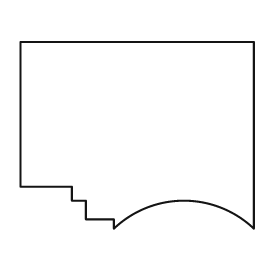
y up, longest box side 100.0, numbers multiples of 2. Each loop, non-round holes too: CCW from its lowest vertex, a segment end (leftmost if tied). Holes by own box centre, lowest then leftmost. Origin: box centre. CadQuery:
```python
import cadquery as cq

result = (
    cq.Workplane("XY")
    .moveTo(-10.0, -40.0)
    .threePointArc((20.0, -28.0), (50.0, -40.0))
    .lineTo(50.0, 40.0)
    .lineTo(-50.0, 40.0)
    .lineTo(-50.0, -22.0)
    .lineTo(-28.0, -22.0)
    .lineTo(-28.0, -28.0)
    .lineTo(-22.0, -28.0)
    .lineTo(-22.0, -36.0)
    .lineTo(-10.0, -36.0)
    .close()
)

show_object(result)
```